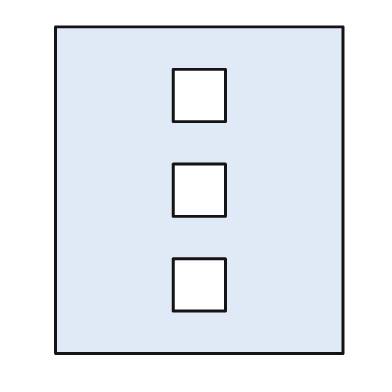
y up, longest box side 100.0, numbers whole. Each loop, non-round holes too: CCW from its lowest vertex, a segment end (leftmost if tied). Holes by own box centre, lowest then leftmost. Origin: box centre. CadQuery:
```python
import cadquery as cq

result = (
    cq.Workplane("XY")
    .moveTo(-44.0, -50.0)
    .lineTo(44.0, -50.0)
    .lineTo(44.0, 50.0)
    .lineTo(-44.0, 50.0)
    .close()
    .moveTo(-8.0, -37.0)
    .lineTo(8.0, -37.0)
    .lineTo(8.0, -21.0)
    .lineTo(-8.0, -21.0)
    .close()
    .moveTo(-8.0, -8.0)
    .lineTo(8.0, -8.0)
    .lineTo(8.0, 8.0)
    .lineTo(-8.0, 8.0)
    .close()
    .moveTo(-8.0, 21.0)
    .lineTo(8.0, 21.0)
    .lineTo(8.0, 37.0)
    .lineTo(-8.0, 37.0)
    .close()
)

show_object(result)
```